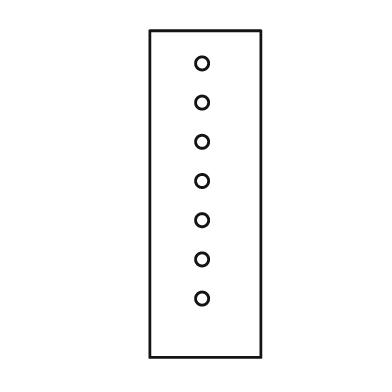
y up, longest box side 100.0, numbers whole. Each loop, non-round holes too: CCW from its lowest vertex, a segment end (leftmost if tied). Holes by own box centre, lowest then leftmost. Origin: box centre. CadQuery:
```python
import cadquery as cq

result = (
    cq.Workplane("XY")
    .moveTo(-17.0, -50.0)
    .lineTo(17.0, -50.0)
    .lineTo(17.0, 50.0)
    .lineTo(-17.0, 50.0)
    .close()
    .moveTo(-1.0, -32.0)
    .circle(2.0)
    .moveTo(-1.0, -20.0)
    .circle(2.0)
    .moveTo(-1.0, -8.0)
    .circle(2.0)
    .moveTo(-1.0, 4.0)
    .circle(2.0)
    .moveTo(-1.0, 16.0)
    .circle(2.0)
    .moveTo(-1.0, 28.0)
    .circle(2.0)
    .moveTo(-1.0, 40.0)
    .circle(2.0)
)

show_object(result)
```